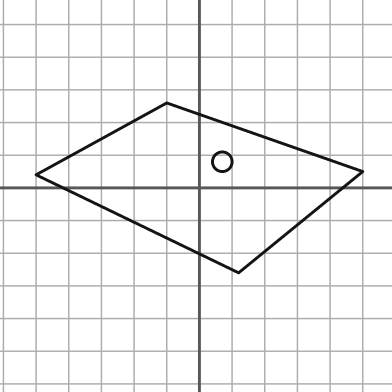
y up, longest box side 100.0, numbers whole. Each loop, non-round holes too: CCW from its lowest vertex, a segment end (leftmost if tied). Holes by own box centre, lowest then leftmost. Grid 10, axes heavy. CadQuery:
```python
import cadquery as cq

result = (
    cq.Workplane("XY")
    .moveTo(12.0, -26.0)
    .lineTo(50.0, 5.0)
    .lineTo(-10.0, 26.0)
    .lineTo(-50.0, 4.0)
    .close()
    .moveTo(7.0, 8.0)
    .circle(3.0)
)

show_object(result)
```